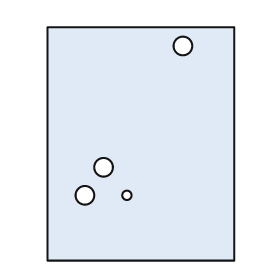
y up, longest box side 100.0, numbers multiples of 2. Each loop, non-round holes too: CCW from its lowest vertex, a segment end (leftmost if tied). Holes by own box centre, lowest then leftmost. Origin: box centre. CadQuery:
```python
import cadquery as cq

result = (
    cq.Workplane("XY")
    .moveTo(-40.0, -50.0)
    .lineTo(40.0, -50.0)
    .lineTo(40.0, 50.0)
    .lineTo(-40.0, 50.0)
    .close()
    .moveTo(-24.0, -22.0)
    .circle(4.0)
    .moveTo(-6.0, -22.0)
    .circle(2.0)
    .moveTo(-16.0, -10.0)
    .circle(4.0)
    .moveTo(18.0, 42.0)
    .circle(4.0)
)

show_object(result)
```